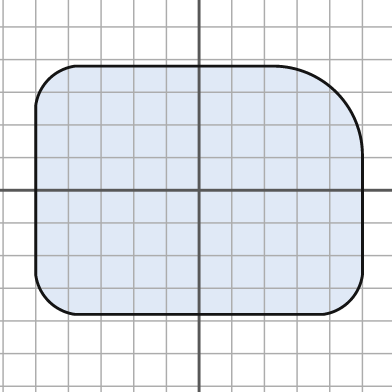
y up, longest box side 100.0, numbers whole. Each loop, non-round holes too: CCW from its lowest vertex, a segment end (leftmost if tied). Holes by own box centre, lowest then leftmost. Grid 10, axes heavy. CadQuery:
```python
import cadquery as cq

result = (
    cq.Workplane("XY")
    .moveTo(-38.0, -38.0)
    .lineTo(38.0, -38.0)
    .threePointArc((46.0, -34.0), (50.0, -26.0))
    .lineTo(50.0, 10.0)
    .threePointArc((42.0, 30.0), (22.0, 38.0))
    .lineTo(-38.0, 38.0)
    .threePointArc((-46.0, 34.0), (-50.0, 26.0))
    .lineTo(-50.0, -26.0)
    .threePointArc((-46.0, -34.0), (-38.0, -38.0))
    .close()
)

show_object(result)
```